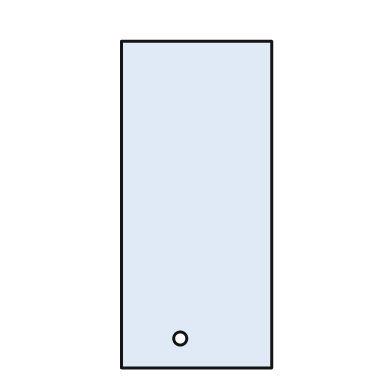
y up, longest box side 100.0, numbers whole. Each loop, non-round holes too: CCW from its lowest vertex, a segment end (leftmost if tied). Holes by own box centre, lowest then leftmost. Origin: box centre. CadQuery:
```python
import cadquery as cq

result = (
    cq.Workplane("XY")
    .moveTo(-23.0, -50.0)
    .lineTo(23.0, -50.0)
    .lineTo(23.0, 50.0)
    .lineTo(-23.0, 50.0)
    .close()
    .moveTo(-5.0, -41.0)
    .circle(2.0)
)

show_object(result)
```